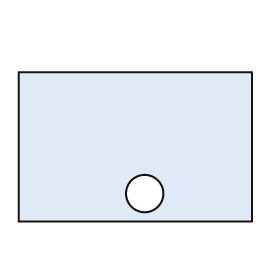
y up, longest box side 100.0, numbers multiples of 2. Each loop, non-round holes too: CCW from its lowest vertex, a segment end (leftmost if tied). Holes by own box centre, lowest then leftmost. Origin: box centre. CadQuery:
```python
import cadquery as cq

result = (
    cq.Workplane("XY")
    .moveTo(-50.0, -32.0)
    .lineTo(50.0, -32.0)
    .lineTo(50.0, 32.0)
    .lineTo(-50.0, 32.0)
    .close()
    .moveTo(4.0, -20.0)
    .circle(8.0)
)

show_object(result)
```